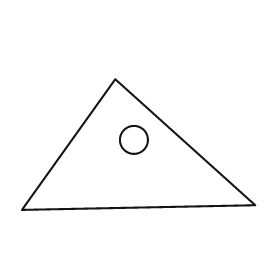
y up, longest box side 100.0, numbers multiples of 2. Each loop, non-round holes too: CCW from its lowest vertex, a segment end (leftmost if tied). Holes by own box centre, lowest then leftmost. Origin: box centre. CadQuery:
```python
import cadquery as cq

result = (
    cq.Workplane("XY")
    .moveTo(-50.0, -28.0)
    .lineTo(50.0, -26.0)
    .lineTo(-10.0, 28.0)
    .close()
    .moveTo(-2.0, 2.0)
    .circle(6.0)
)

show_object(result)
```